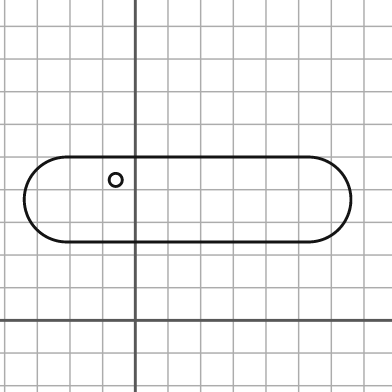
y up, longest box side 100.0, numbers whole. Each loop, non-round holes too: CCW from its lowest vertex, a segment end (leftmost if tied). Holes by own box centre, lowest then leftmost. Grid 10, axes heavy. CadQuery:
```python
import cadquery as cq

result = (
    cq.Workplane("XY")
    .moveTo(-21.0, 24.0)
    .lineTo(53.0, 24.0)
    .threePointArc((66.0, 37.0), (53.0, 50.0))
    .lineTo(-21.0, 50.0)
    .threePointArc((-34.0, 37.0), (-21.0, 24.0))
    .close()
    .moveTo(-6.0, 43.0)
    .circle(2.0)
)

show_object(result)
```